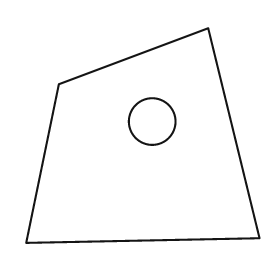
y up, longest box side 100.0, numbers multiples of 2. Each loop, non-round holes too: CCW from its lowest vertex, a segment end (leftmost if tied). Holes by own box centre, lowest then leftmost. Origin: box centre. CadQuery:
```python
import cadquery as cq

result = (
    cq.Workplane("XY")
    .moveTo(-50.0, -46.0)
    .lineTo(50.0, -44.0)
    .lineTo(28.0, 46.0)
    .lineTo(-36.0, 22.0)
    .close()
    .moveTo(4.0, 6.0)
    .circle(10.0)
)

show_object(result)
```